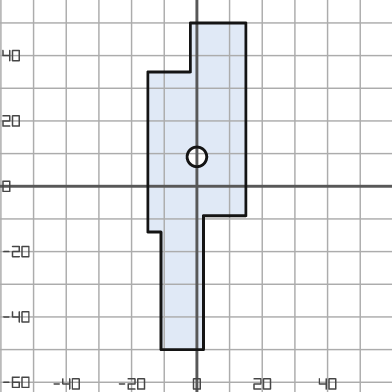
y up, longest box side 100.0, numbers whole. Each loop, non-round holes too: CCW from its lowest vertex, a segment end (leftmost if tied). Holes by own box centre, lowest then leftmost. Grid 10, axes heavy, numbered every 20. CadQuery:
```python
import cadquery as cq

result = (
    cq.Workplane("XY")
    .moveTo(-11.0, -50.0)
    .lineTo(2.0, -50.0)
    .lineTo(2.0, -9.0)
    .lineTo(15.0, -9.0)
    .lineTo(15.0, 50.0)
    .lineTo(-2.0, 50.0)
    .lineTo(-2.0, 35.0)
    .lineTo(-15.0, 35.0)
    .lineTo(-15.0, -14.0)
    .lineTo(-11.0, -14.0)
    .close()
    .moveTo(0.0, 9.0)
    .circle(3.0)
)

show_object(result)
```